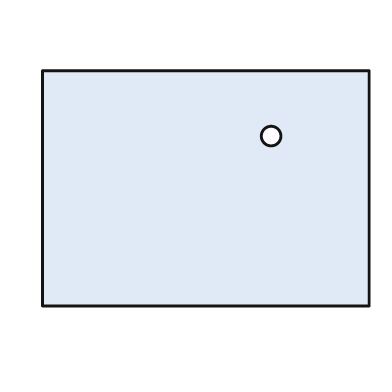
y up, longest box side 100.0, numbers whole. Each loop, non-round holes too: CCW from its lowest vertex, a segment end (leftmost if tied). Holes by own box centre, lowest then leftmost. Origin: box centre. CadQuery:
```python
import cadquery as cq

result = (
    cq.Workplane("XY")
    .moveTo(-50.0, -36.0)
    .lineTo(50.0, -36.0)
    .lineTo(50.0, 36.0)
    .lineTo(-50.0, 36.0)
    .close()
    .moveTo(20.0, 16.0)
    .circle(3.0)
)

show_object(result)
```